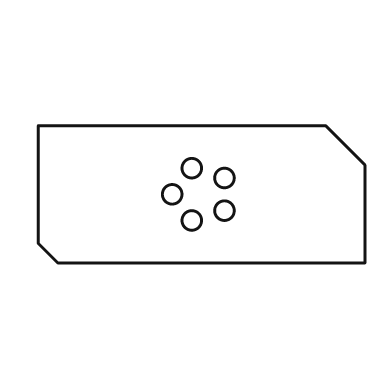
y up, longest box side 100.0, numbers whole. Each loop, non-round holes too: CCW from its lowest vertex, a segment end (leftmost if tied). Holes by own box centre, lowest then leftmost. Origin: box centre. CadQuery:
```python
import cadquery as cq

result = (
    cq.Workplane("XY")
    .moveTo(-44.0, -21.0)
    .lineTo(50.0, -21.0)
    .lineTo(50.0, 9.0)
    .lineTo(38.0, 21.0)
    .lineTo(-50.0, 21.0)
    .lineTo(-50.0, -15.0)
    .close()
    .moveTo(-3.0, -8.0)
    .circle(3.0)
    .moveTo(7.0, -5.0)
    .circle(3.0)
    .moveTo(-9.0, 0.0)
    .circle(3.0)
    .moveTo(7.0, 5.0)
    .circle(3.0)
    .moveTo(-3.0, 8.0)
    .circle(3.0)
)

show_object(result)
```